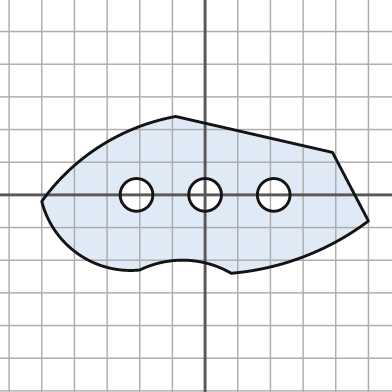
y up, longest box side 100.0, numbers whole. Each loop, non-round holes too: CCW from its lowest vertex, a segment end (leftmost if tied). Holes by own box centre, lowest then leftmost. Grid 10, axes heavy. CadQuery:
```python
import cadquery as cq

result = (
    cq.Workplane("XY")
    .moveTo(8.0, -24.0)
    .threePointArc((30.0, -19.0), (50.0, -8.0))
    .lineTo(39.0, 13.0)
    .lineTo(-9.0, 24.0)
    .threePointArc((-32.0, 15.0), (-50.0, -2.0))
    .threePointArc((-39.0, -18.0), (-20.0, -23.0))
    .threePointArc((-6.0, -20.0), (8.0, -24.0))
    .close()
    .moveTo(-21.0, 0.0)
    .circle(5.0)
    .moveTo(0.0, 0.0)
    .circle(5.0)
    .moveTo(21.0, 0.0)
    .circle(5.0)
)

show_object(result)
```